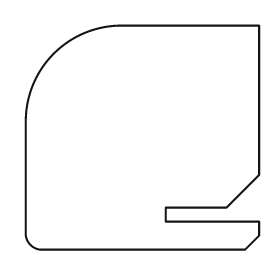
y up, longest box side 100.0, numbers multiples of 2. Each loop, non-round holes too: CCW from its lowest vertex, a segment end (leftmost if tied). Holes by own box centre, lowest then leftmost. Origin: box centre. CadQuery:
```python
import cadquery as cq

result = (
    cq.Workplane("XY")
    .moveTo(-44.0, -48.0)
    .lineTo(44.0, -48.0)
    .lineTo(50.0, -42.0)
    .lineTo(50.0, -36.0)
    .lineTo(10.0, -36.0)
    .lineTo(10.0, -30.0)
    .lineTo(36.0, -30.0)
    .lineTo(50.0, -16.0)
    .lineTo(50.0, 48.0)
    .lineTo(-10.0, 48.0)
    .threePointArc((-38.0, 36.0), (-50.0, 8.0))
    .lineTo(-50.0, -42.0)
    .threePointArc((-48.0, -46.0), (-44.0, -48.0))
    .close()
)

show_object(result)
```